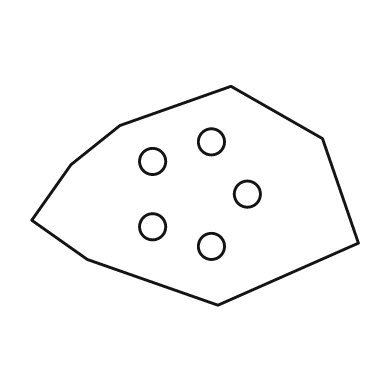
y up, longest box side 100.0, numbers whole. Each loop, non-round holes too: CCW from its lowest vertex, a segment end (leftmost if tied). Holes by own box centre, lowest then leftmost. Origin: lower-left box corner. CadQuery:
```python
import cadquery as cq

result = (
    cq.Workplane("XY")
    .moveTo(57.0, 0.0)
    .lineTo(100.0, 19.0)
    .lineTo(89.0, 51.0)
    .lineTo(61.0, 67.0)
    .lineTo(27.0, 55.0)
    .lineTo(12.0, 43.0)
    .lineTo(0.0, 26.0)
    .lineTo(17.0, 14.0)
    .close()
    .moveTo(55.0, 18.0)
    .circle(4.0)
    .moveTo(37.0, 24.0)
    .circle(4.0)
    .moveTo(66.0, 34.0)
    .circle(4.0)
    .moveTo(37.0, 44.0)
    .circle(4.0)
    .moveTo(55.0, 50.0)
    .circle(4.0)
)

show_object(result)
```